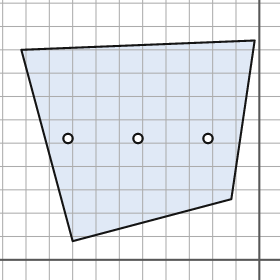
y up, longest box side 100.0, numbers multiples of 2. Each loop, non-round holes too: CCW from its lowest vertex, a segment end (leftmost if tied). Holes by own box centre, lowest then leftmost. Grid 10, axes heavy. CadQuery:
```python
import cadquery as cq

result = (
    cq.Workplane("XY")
    .moveTo(-80.0, 8.0)
    .lineTo(-12.0, 26.0)
    .lineTo(-2.0, 94.0)
    .lineTo(-102.0, 90.0)
    .close()
    .moveTo(-82.0, 52.0)
    .circle(2.0)
    .moveTo(-52.0, 52.0)
    .circle(2.0)
    .moveTo(-22.0, 52.0)
    .circle(2.0)
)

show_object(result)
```